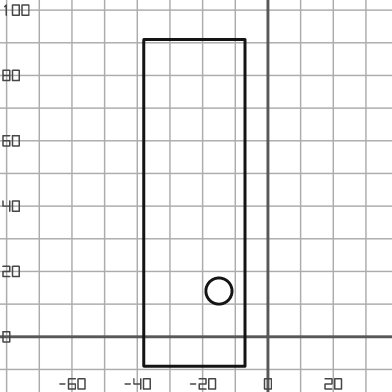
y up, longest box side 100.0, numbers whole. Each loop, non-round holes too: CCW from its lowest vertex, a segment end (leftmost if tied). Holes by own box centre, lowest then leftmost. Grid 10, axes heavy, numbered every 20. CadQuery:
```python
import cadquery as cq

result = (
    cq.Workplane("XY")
    .moveTo(-38.0, -9.0)
    .lineTo(-7.0, -9.0)
    .lineTo(-7.0, 91.0)
    .lineTo(-38.0, 91.0)
    .close()
    .moveTo(-15.0, 14.0)
    .circle(4.0)
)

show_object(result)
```